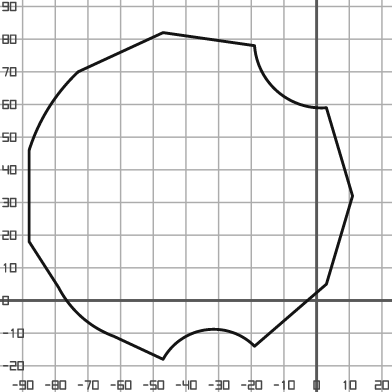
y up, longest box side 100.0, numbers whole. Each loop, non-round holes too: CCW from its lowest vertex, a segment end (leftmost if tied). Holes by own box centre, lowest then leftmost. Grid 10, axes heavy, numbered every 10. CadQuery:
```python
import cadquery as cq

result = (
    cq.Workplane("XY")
    .moveTo(-47.0, -18.0)
    .threePointArc((-34.0, -9.0), (-19.0, -14.0))
    .lineTo(3.0, 5.0)
    .lineTo(11.0, 32.0)
    .lineTo(3.0, 59.0)
    .threePointArc((-12.0, 64.0), (-19.0, 78.0))
    .lineTo(-47.0, 82.0)
    .lineTo(-73.0, 70.0)
    .threePointArc((-82.0, 59.0), (-88.0, 46.0))
    .lineTo(-88.0, 18.0)
    .lineTo(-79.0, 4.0)
    .threePointArc((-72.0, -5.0), (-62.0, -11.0))
    .close()
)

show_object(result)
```